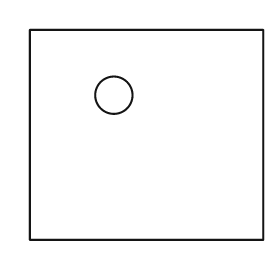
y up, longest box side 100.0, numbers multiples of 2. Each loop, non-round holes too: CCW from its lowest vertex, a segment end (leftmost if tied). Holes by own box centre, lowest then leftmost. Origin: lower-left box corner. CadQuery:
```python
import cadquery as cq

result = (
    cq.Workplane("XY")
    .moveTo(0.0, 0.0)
    .lineTo(100.0, 0.0)
    .lineTo(100.0, 90.0)
    .lineTo(0.0, 90.0)
    .close()
    .moveTo(36.0, 62.0)
    .circle(8.0)
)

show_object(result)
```